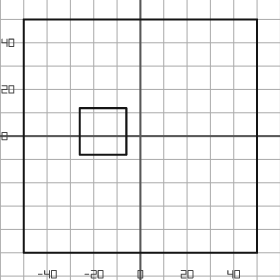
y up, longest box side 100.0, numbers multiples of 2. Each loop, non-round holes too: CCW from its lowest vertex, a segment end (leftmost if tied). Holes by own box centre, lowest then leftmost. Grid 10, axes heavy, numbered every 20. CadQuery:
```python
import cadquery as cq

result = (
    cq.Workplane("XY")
    .moveTo(-50.0, -50.0)
    .lineTo(50.0, -50.0)
    .lineTo(50.0, 50.0)
    .lineTo(-50.0, 50.0)
    .close()
    .moveTo(-26.0, -8.0)
    .lineTo(-6.0, -8.0)
    .lineTo(-6.0, 12.0)
    .lineTo(-26.0, 12.0)
    .close()
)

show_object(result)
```